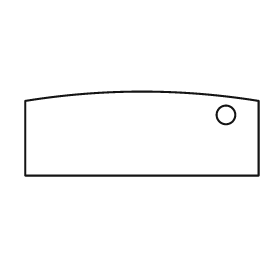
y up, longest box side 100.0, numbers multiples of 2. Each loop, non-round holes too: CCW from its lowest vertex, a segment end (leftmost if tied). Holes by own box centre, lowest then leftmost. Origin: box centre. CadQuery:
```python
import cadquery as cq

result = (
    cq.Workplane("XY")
    .moveTo(-50.0, -18.0)
    .lineTo(50.0, -18.0)
    .lineTo(50.0, 14.0)
    .threePointArc((0.0, 18.0), (-50.0, 14.0))
    .close()
    .moveTo(36.0, 8.0)
    .circle(4.0)
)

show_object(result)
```